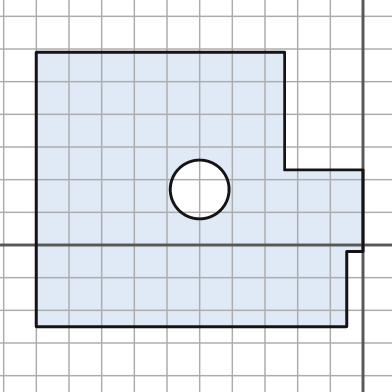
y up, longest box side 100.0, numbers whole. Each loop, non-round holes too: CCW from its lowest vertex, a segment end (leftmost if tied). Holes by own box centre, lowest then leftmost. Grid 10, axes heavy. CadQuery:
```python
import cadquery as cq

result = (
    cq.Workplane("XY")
    .moveTo(-100.0, -25.0)
    .lineTo(-5.0, -25.0)
    .lineTo(-5.0, -2.0)
    .lineTo(0.0, -2.0)
    .lineTo(0.0, 23.0)
    .lineTo(-24.0, 23.0)
    .lineTo(-24.0, 59.0)
    .lineTo(-100.0, 59.0)
    .close()
    .moveTo(-50.0, 17.0)
    .circle(9.0)
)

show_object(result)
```